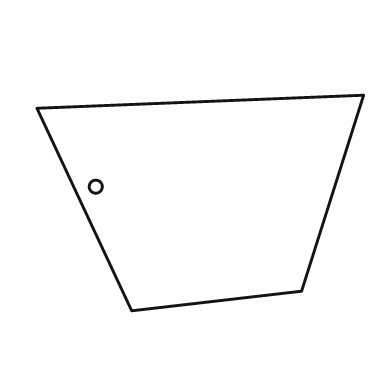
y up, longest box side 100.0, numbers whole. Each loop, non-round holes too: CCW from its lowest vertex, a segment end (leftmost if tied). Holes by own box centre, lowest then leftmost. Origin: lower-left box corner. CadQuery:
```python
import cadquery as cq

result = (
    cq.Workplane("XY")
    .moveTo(29.0, 0.0)
    .lineTo(81.0, 6.0)
    .lineTo(100.0, 66.0)
    .lineTo(0.0, 62.0)
    .close()
    .moveTo(18.0, 38.0)
    .circle(2.0)
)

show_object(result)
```